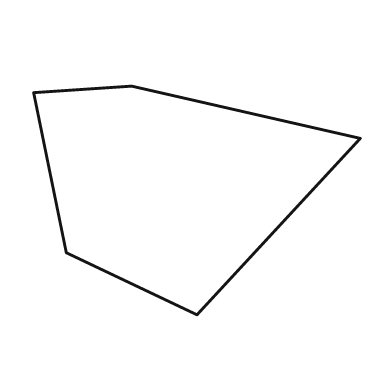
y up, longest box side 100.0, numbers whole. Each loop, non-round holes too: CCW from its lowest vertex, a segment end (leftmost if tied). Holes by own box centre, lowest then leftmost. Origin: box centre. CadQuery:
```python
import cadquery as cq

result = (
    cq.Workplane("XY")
    .moveTo(0.0, -35.0)
    .lineTo(50.0, 19.0)
    .lineTo(-20.0, 35.0)
    .lineTo(-50.0, 33.0)
    .lineTo(-40.0, -16.0)
    .close()
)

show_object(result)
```